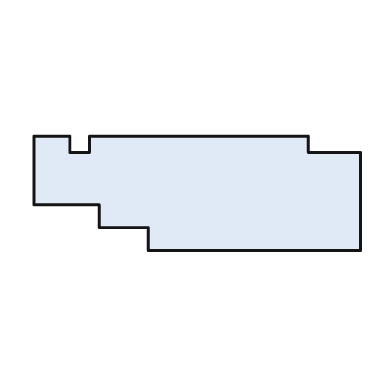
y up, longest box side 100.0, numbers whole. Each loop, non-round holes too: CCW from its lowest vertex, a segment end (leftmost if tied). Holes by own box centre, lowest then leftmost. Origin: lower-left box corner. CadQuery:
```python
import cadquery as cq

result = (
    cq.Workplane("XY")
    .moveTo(35.0, 0.0)
    .lineTo(100.0, 0.0)
    .lineTo(100.0, 30.0)
    .lineTo(84.0, 30.0)
    .lineTo(84.0, 35.0)
    .lineTo(17.0, 35.0)
    .lineTo(17.0, 30.0)
    .lineTo(11.0, 30.0)
    .lineTo(11.0, 35.0)
    .lineTo(0.0, 35.0)
    .lineTo(0.0, 14.0)
    .lineTo(20.0, 14.0)
    .lineTo(20.0, 7.0)
    .lineTo(35.0, 7.0)
    .close()
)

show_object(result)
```